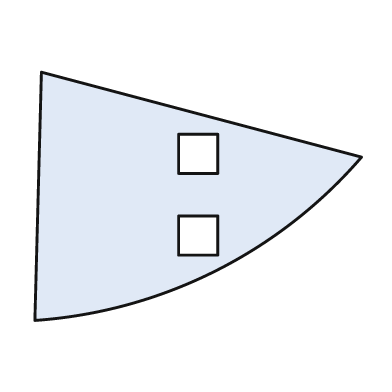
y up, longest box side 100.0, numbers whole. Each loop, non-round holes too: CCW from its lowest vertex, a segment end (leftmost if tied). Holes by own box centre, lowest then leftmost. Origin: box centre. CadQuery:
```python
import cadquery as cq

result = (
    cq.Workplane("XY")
    .moveTo(-50.0, -38.0)
    .threePointArc((5.0, -23.0), (50.0, 12.0))
    .lineTo(-48.0, 38.0)
    .close()
    .moveTo(-6.0, -18.0)
    .lineTo(6.0, -18.0)
    .lineTo(6.0, -6.0)
    .lineTo(-6.0, -6.0)
    .close()
    .moveTo(-6.0, 7.0)
    .lineTo(6.0, 7.0)
    .lineTo(6.0, 19.0)
    .lineTo(-6.0, 19.0)
    .close()
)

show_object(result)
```